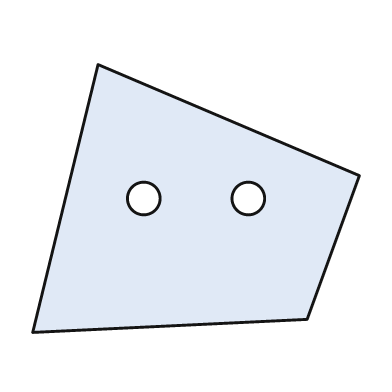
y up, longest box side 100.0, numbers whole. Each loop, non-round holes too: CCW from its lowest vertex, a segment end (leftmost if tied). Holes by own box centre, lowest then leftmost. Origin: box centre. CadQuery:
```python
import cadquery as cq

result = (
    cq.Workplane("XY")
    .moveTo(-50.0, -41.0)
    .lineTo(34.0, -37.0)
    .lineTo(50.0, 7.0)
    .lineTo(-30.0, 41.0)
    .close()
    .moveTo(-16.0, 0.0)
    .circle(5.0)
    .moveTo(16.0, 0.0)
    .circle(5.0)
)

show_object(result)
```